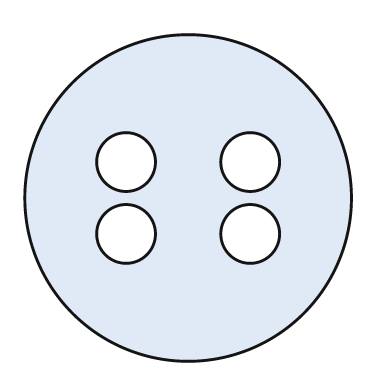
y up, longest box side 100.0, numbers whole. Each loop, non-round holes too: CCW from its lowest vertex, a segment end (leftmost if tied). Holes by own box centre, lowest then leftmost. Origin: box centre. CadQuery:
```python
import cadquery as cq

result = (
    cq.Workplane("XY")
    .moveTo(0.0, 0.0)
    .circle(50.0)
    .moveTo(-19.0, -11.0)
    .circle(9.0)
    .moveTo(19.0, -11.0)
    .circle(9.0)
    .moveTo(-19.0, 11.0)
    .circle(9.0)
    .moveTo(19.0, 11.0)
    .circle(9.0)
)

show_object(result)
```